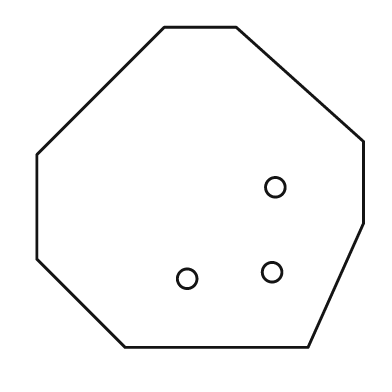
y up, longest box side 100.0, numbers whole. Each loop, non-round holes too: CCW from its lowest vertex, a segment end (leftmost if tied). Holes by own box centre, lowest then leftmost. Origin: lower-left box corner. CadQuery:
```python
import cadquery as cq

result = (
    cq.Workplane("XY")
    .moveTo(27.0, 0.0)
    .lineTo(83.0, 0.0)
    .lineTo(100.0, 38.0)
    .lineTo(100.0, 63.0)
    .lineTo(61.0, 98.0)
    .lineTo(39.0, 98.0)
    .lineTo(0.0, 59.0)
    .lineTo(0.0, 27.0)
    .close()
    .moveTo(46.0, 21.0)
    .circle(3.0)
    .moveTo(72.0, 23.0)
    .circle(3.0)
    .moveTo(73.0, 49.0)
    .circle(3.0)
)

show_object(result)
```